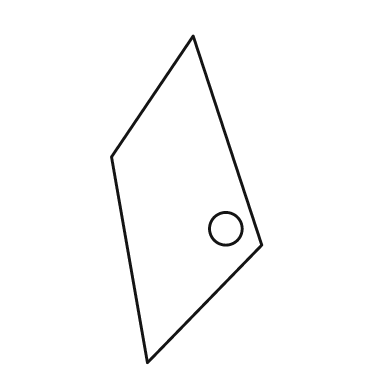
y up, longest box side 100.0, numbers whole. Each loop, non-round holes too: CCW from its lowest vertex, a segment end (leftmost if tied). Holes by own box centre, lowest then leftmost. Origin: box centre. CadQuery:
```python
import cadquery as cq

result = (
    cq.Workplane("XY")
    .moveTo(-12.0, -50.0)
    .lineTo(23.0, -14.0)
    .lineTo(2.0, 50.0)
    .lineTo(-23.0, 13.0)
    .close()
    .moveTo(12.0, -9.0)
    .circle(5.0)
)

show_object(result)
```